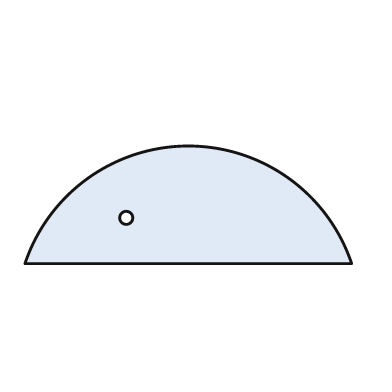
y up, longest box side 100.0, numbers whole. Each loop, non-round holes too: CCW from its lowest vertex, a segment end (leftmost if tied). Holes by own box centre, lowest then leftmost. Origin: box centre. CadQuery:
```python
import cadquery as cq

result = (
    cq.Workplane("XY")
    .moveTo(-50.0, -18.0)
    .lineTo(50.0, -18.0)
    .threePointArc((0.0, 18.0), (-50.0, -18.0))
    .close()
    .moveTo(-19.0, -4.0)
    .circle(2.0)
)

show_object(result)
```